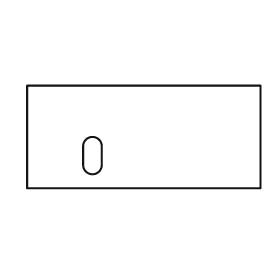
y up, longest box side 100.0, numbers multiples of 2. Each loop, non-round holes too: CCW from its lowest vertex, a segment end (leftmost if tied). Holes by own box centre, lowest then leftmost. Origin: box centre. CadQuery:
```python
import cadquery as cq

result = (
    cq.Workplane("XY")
    .moveTo(-50.0, -22.0)
    .lineTo(50.0, -22.0)
    .lineTo(50.0, 22.0)
    .lineTo(-50.0, 22.0)
    .close()
    .moveTo(-26.0, -12.0)
    .threePointArc((-22.0, -16.0), (-18.0, -12.0))
    .lineTo(-18.0, -4.0)
    .threePointArc((-22.0, 0.0), (-26.0, -4.0))
    .close()
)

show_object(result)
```